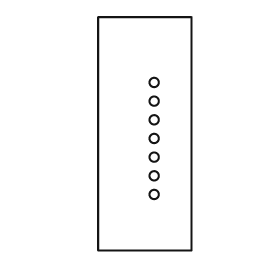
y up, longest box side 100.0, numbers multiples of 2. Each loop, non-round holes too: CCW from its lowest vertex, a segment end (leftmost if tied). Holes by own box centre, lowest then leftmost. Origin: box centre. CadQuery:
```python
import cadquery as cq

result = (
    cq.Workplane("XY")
    .moveTo(-20.0, -50.0)
    .lineTo(20.0, -50.0)
    .lineTo(20.0, 50.0)
    .lineTo(-20.0, 50.0)
    .close()
    .moveTo(4.0, -26.0)
    .circle(2.0)
    .moveTo(4.0, -18.0)
    .circle(2.0)
    .moveTo(4.0, -10.0)
    .circle(2.0)
    .moveTo(4.0, -2.0)
    .circle(2.0)
    .moveTo(4.0, 6.0)
    .circle(2.0)
    .moveTo(4.0, 14.0)
    .circle(2.0)
    .moveTo(4.0, 22.0)
    .circle(2.0)
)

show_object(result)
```